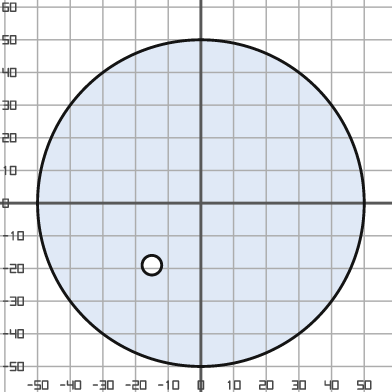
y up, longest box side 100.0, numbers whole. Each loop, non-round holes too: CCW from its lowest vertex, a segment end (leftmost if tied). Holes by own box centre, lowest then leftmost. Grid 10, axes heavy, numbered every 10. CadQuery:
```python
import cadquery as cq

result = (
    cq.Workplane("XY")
    .moveTo(0.0, 0.0)
    .circle(50.0)
    .moveTo(-15.0, -19.0)
    .circle(3.0)
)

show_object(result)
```